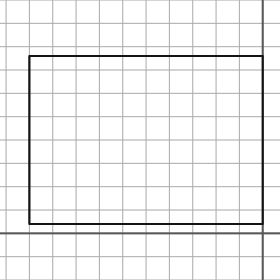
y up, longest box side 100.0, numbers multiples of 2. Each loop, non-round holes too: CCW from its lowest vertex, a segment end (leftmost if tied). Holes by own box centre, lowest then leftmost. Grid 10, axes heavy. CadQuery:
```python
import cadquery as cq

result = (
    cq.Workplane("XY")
    .moveTo(-100.0, 4.0)
    .lineTo(0.0, 4.0)
    .lineTo(0.0, 76.0)
    .lineTo(-100.0, 76.0)
    .close()
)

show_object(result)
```